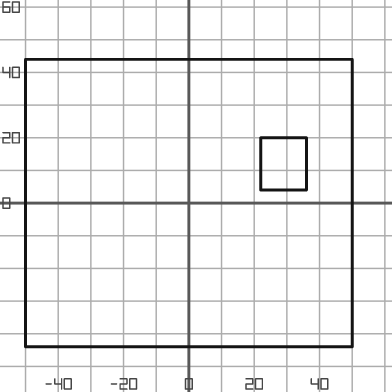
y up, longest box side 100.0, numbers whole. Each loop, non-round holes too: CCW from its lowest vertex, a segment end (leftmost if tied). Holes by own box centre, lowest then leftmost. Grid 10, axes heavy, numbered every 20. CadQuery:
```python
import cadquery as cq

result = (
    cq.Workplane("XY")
    .moveTo(-50.0, -44.0)
    .lineTo(50.0, -44.0)
    .lineTo(50.0, 44.0)
    .lineTo(-50.0, 44.0)
    .close()
    .moveTo(22.0, 4.0)
    .lineTo(36.0, 4.0)
    .lineTo(36.0, 20.0)
    .lineTo(22.0, 20.0)
    .close()
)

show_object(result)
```